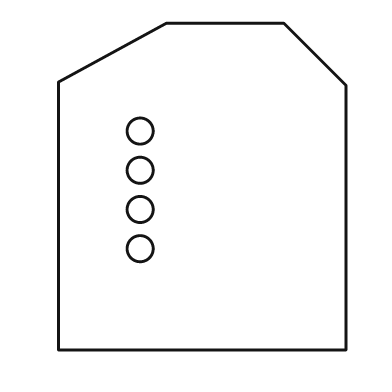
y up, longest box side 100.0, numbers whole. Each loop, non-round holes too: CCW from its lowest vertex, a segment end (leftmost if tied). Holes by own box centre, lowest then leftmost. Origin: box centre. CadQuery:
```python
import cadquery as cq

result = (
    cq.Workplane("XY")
    .moveTo(-44.0, -50.0)
    .lineTo(44.0, -50.0)
    .lineTo(44.0, 31.0)
    .lineTo(25.0, 50.0)
    .lineTo(-11.0, 50.0)
    .lineTo(-44.0, 32.0)
    .close()
    .moveTo(-19.0, -19.0)
    .circle(4.0)
    .moveTo(-19.0, -7.0)
    .circle(4.0)
    .moveTo(-19.0, 5.0)
    .circle(4.0)
    .moveTo(-19.0, 17.0)
    .circle(4.0)
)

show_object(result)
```